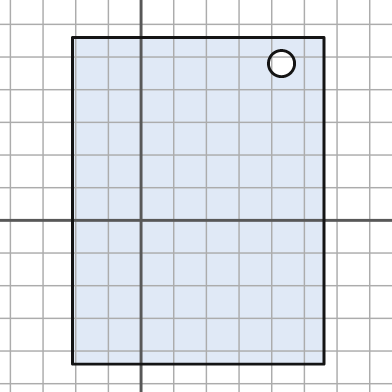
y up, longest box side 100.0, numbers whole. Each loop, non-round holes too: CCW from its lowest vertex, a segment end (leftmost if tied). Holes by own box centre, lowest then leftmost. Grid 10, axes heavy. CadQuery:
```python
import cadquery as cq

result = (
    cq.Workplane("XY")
    .moveTo(-21.0, -44.0)
    .lineTo(56.0, -44.0)
    .lineTo(56.0, 56.0)
    .lineTo(-21.0, 56.0)
    .close()
    .moveTo(43.0, 48.0)
    .circle(4.0)
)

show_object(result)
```